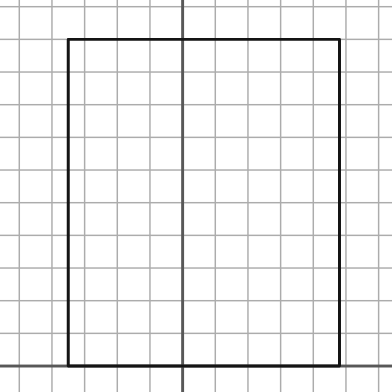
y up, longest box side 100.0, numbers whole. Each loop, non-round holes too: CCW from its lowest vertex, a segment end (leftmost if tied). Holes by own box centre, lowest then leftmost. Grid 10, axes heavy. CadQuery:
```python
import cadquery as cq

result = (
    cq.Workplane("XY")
    .moveTo(-35.0, 0.0)
    .lineTo(48.0, 0.0)
    .lineTo(48.0, 100.0)
    .lineTo(-35.0, 100.0)
    .close()
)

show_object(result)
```